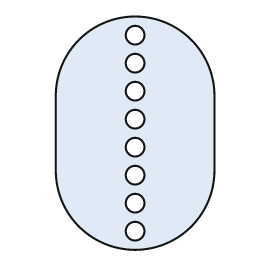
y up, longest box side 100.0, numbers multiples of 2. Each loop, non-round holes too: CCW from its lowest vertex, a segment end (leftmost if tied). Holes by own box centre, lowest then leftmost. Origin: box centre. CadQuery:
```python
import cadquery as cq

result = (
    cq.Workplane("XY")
    .moveTo(-34.0, -16.0)
    .threePointArc((0.0, -50.0), (34.0, -16.0))
    .lineTo(34.0, 16.0)
    .threePointArc((0.0, 50.0), (-34.0, 16.0))
    .close()
    .moveTo(0.0, -42.0)
    .circle(4.0)
    .moveTo(0.0, -30.0)
    .circle(4.0)
    .moveTo(0.0, -18.0)
    .circle(4.0)
    .moveTo(0.0, -6.0)
    .circle(4.0)
    .moveTo(0.0, 6.0)
    .circle(4.0)
    .moveTo(0.0, 18.0)
    .circle(4.0)
    .moveTo(0.0, 30.0)
    .circle(4.0)
    .moveTo(0.0, 42.0)
    .circle(4.0)
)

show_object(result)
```